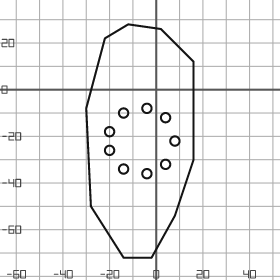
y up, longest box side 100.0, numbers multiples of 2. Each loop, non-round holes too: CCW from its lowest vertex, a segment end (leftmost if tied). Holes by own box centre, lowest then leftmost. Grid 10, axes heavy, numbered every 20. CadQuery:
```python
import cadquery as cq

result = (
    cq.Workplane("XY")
    .moveTo(-14.0, -72.0)
    .lineTo(-2.0, -72.0)
    .lineTo(8.0, -54.0)
    .lineTo(16.0, -30.0)
    .lineTo(16.0, 12.0)
    .lineTo(2.0, 26.0)
    .lineTo(-12.0, 28.0)
    .lineTo(-22.0, 22.0)
    .lineTo(-30.0, -8.0)
    .lineTo(-28.0, -50.0)
    .close()
    .moveTo(-4.0, -36.0)
    .circle(2.0)
    .moveTo(-14.0, -34.0)
    .circle(2.0)
    .moveTo(4.0, -32.0)
    .circle(2.0)
    .moveTo(-20.0, -26.0)
    .circle(2.0)
    .moveTo(8.0, -22.0)
    .circle(2.0)
    .moveTo(-20.0, -18.0)
    .circle(2.0)
    .moveTo(4.0, -12.0)
    .circle(2.0)
    .moveTo(-14.0, -10.0)
    .circle(2.0)
    .moveTo(-4.0, -8.0)
    .circle(2.0)
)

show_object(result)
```